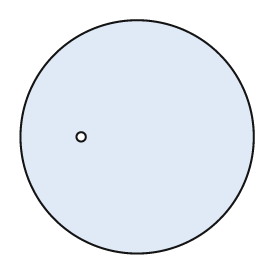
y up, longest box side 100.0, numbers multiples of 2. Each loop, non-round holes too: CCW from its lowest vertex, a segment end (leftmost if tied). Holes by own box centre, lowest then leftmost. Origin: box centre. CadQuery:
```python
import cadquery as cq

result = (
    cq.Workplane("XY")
    .moveTo(0.0, 0.0)
    .circle(50.0)
    .moveTo(-24.0, 0.0)
    .circle(2.0)
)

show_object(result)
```